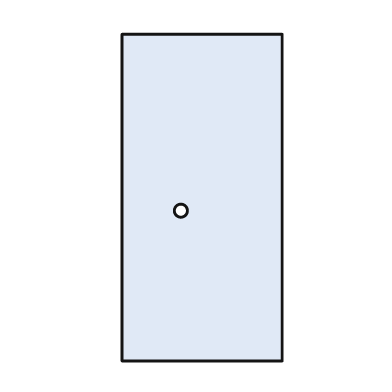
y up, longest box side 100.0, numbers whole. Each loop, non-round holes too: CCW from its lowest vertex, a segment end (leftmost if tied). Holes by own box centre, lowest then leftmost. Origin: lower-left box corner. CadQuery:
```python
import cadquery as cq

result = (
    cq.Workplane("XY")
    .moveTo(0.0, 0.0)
    .lineTo(49.0, 0.0)
    .lineTo(49.0, 100.0)
    .lineTo(0.0, 100.0)
    .close()
    .moveTo(18.0, 46.0)
    .circle(2.0)
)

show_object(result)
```